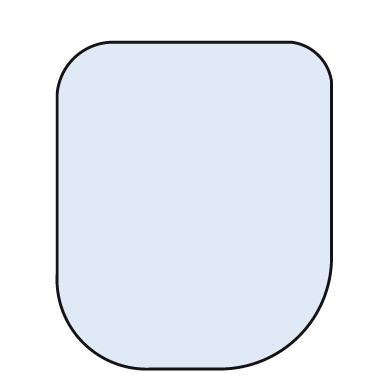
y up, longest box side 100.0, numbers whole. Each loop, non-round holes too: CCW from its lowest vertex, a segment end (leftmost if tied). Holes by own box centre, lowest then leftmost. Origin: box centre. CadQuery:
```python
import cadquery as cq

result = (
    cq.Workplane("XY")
    .moveTo(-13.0, -50.0)
    .lineTo(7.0, -50.0)
    .threePointArc((32.0, -40.0), (42.0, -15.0))
    .lineTo(42.0, 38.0)
    .threePointArc((38.0, 46.0), (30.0, 50.0))
    .lineTo(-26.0, 50.0)
    .threePointArc((-37.0, 45.0), (-42.0, 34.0))
    .lineTo(-42.0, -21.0)
    .threePointArc((-34.0, -42.0), (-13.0, -50.0))
    .close()
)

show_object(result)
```